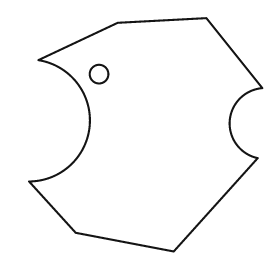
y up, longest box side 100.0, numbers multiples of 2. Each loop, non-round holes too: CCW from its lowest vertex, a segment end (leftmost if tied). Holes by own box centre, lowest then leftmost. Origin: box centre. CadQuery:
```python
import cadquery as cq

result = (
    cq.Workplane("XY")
    .moveTo(12.0, -50.0)
    .lineTo(48.0, -10.0)
    .threePointArc((36.0, 6.0), (50.0, 20.0))
    .lineTo(26.0, 50.0)
    .lineTo(-12.0, 48.0)
    .lineTo(-46.0, 32.0)
    .threePointArc((-24.0, 4.0), (-50.0, -20.0))
    .lineTo(-30.0, -42.0)
    .close()
    .moveTo(-20.0, 26.0)
    .circle(4.0)
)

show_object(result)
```